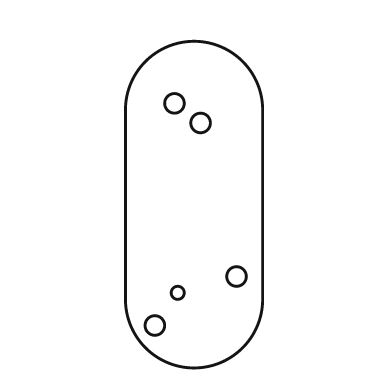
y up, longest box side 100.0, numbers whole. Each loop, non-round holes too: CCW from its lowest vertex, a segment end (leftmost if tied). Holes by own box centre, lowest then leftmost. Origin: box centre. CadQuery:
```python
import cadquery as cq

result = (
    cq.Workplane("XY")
    .moveTo(-21.0, -29.0)
    .threePointArc((0.0, -50.0), (21.0, -29.0))
    .lineTo(21.0, 29.0)
    .threePointArc((0.0, 50.0), (-21.0, 29.0))
    .close()
    .moveTo(-12.0, -37.0)
    .circle(3.0)
    .moveTo(-5.0, -27.0)
    .circle(2.0)
    .moveTo(13.0, -22.0)
    .circle(3.0)
    .moveTo(2.0, 25.0)
    .circle(3.0)
    .moveTo(-6.0, 31.0)
    .circle(3.0)
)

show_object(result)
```